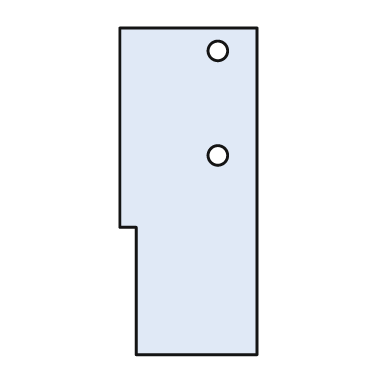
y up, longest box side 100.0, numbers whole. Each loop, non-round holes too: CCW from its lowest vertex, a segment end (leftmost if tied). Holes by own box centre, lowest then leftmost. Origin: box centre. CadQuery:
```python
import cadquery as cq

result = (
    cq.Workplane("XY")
    .moveTo(-16.0, -50.0)
    .lineTo(21.0, -50.0)
    .lineTo(21.0, 50.0)
    .lineTo(-21.0, 50.0)
    .lineTo(-21.0, -11.0)
    .lineTo(-16.0, -11.0)
    .close()
    .moveTo(9.0, 11.0)
    .circle(3.0)
    .moveTo(9.0, 43.0)
    .circle(3.0)
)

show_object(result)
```